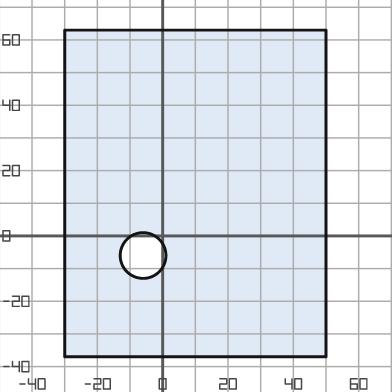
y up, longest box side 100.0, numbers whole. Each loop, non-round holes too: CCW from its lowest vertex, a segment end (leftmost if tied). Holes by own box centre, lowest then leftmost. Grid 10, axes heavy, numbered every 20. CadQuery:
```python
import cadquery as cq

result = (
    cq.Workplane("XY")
    .moveTo(-30.0, -37.0)
    .lineTo(50.0, -37.0)
    .lineTo(50.0, 63.0)
    .lineTo(-30.0, 63.0)
    .close()
    .moveTo(-6.0, -6.0)
    .circle(7.0)
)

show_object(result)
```